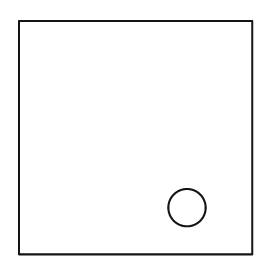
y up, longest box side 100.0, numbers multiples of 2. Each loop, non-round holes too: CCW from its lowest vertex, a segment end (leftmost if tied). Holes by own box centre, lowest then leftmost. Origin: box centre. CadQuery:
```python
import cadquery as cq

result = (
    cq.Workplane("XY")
    .moveTo(-50.0, -50.0)
    .lineTo(50.0, -50.0)
    .lineTo(50.0, 50.0)
    .lineTo(-50.0, 50.0)
    .close()
    .moveTo(22.0, -30.0)
    .circle(8.0)
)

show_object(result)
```